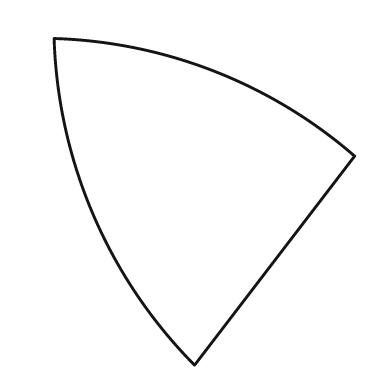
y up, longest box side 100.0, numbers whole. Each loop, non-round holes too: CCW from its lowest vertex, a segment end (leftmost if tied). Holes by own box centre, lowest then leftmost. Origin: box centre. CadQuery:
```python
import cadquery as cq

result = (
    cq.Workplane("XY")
    .moveTo(-3.0, -50.0)
    .lineTo(46.0, 14.0)
    .threePointArc((3.0, 40.0), (-46.0, 50.0))
    .threePointArc((-34.0, -4.0), (-3.0, -50.0))
    .close()
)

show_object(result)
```